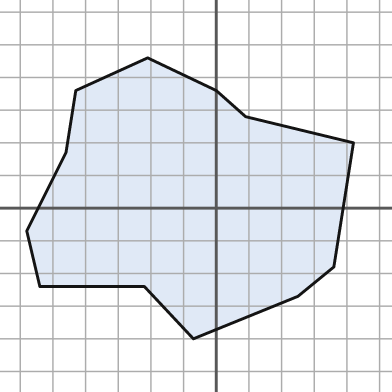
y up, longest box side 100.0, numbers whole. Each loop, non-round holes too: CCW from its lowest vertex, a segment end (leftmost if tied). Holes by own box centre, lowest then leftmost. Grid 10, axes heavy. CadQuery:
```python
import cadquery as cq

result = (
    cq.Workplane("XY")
    .moveTo(-7.0, -40.0)
    .lineTo(25.0, -27.0)
    .lineTo(36.0, -18.0)
    .lineTo(42.0, 20.0)
    .lineTo(9.0, 28.0)
    .lineTo(0.0, 36.0)
    .lineTo(-21.0, 46.0)
    .lineTo(-43.0, 36.0)
    .lineTo(-46.0, 17.0)
    .lineTo(-58.0, -7.0)
    .lineTo(-54.0, -24.0)
    .lineTo(-22.0, -24.0)
    .close()
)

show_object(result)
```